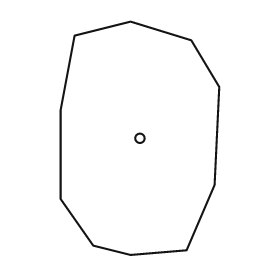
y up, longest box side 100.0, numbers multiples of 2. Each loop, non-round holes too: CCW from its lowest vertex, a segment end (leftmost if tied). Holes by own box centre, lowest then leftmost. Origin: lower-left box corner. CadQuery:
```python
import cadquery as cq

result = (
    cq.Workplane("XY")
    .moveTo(30.0, 0.0)
    .lineTo(54.0, 2.0)
    .lineTo(66.0, 30.0)
    .lineTo(68.0, 72.0)
    .lineTo(56.0, 92.0)
    .lineTo(30.0, 100.0)
    .lineTo(6.0, 94.0)
    .lineTo(0.0, 62.0)
    .lineTo(0.0, 24.0)
    .lineTo(14.0, 4.0)
    .close()
    .moveTo(34.0, 50.0)
    .circle(2.0)
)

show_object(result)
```